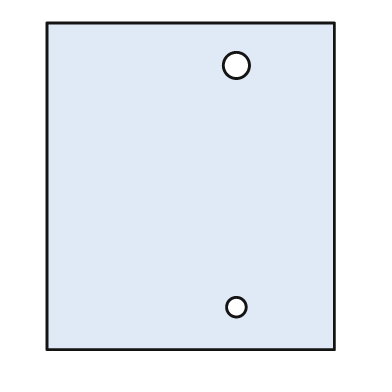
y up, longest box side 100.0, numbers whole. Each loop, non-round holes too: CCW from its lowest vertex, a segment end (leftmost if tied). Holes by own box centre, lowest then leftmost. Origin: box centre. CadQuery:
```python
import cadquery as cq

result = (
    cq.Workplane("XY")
    .moveTo(-44.0, -50.0)
    .lineTo(44.0, -50.0)
    .lineTo(44.0, 50.0)
    .lineTo(-44.0, 50.0)
    .close()
    .moveTo(14.0, -37.0)
    .circle(3.0)
    .moveTo(14.0, 37.0)
    .circle(4.0)
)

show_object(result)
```